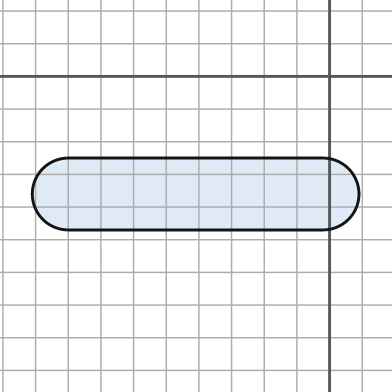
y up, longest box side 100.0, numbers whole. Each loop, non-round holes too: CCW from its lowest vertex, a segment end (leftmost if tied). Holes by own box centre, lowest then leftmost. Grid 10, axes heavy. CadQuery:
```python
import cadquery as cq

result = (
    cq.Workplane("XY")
    .moveTo(-80.0, -47.0)
    .lineTo(-2.0, -47.0)
    .threePointArc((9.0, -36.0), (-2.0, -25.0))
    .lineTo(-80.0, -25.0)
    .threePointArc((-91.0, -36.0), (-80.0, -47.0))
    .close()
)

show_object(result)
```